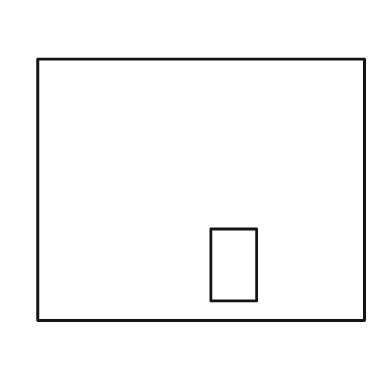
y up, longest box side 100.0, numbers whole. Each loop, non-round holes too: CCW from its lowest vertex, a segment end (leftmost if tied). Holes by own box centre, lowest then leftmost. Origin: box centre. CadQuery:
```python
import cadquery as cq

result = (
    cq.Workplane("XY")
    .moveTo(-50.0, -40.0)
    .lineTo(50.0, -40.0)
    .lineTo(50.0, 40.0)
    .lineTo(-50.0, 40.0)
    .close()
    .moveTo(3.0, -34.0)
    .lineTo(17.0, -34.0)
    .lineTo(17.0, -12.0)
    .lineTo(3.0, -12.0)
    .close()
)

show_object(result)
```